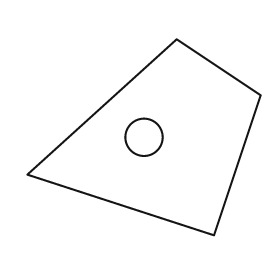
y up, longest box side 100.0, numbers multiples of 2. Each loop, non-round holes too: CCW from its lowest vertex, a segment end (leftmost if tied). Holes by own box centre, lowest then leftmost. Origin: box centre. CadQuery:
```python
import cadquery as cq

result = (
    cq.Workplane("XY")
    .moveTo(30.0, -42.0)
    .lineTo(50.0, 18.0)
    .lineTo(14.0, 42.0)
    .lineTo(-50.0, -16.0)
    .close()
    .moveTo(0.0, 0.0)
    .circle(8.0)
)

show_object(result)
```